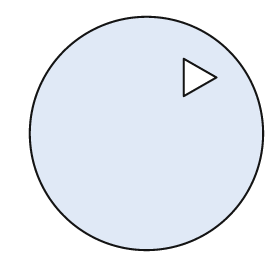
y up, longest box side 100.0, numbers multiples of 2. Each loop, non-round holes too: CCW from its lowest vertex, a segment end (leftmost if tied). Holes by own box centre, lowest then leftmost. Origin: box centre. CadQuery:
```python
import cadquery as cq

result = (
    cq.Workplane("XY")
    .moveTo(0.0, 0.0)
    .circle(50.0)
    .moveTo(16.0, 16.0)
    .lineTo(30.0, 24.0)
    .lineTo(16.0, 32.0)
    .close()
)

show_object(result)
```